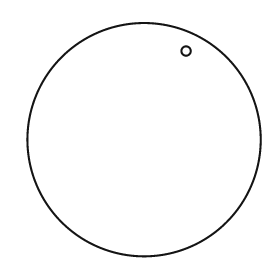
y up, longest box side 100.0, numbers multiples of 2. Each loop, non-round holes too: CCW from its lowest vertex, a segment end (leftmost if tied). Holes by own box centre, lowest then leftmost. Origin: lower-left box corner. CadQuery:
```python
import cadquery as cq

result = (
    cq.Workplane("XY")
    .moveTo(50.0, 50.0)
    .circle(50.0)
    .moveTo(68.0, 88.0)
    .circle(2.0)
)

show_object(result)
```